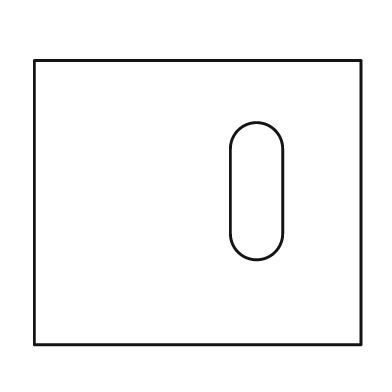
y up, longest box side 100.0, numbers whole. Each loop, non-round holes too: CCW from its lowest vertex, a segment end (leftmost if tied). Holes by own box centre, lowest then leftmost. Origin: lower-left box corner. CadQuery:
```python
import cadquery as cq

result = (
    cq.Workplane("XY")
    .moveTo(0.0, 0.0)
    .lineTo(100.0, 0.0)
    .lineTo(100.0, 87.0)
    .lineTo(0.0, 87.0)
    .close()
    .moveTo(60.0, 34.0)
    .threePointArc((68.0, 26.0), (76.0, 34.0))
    .lineTo(76.0, 60.0)
    .threePointArc((68.0, 68.0), (60.0, 60.0))
    .close()
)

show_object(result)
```